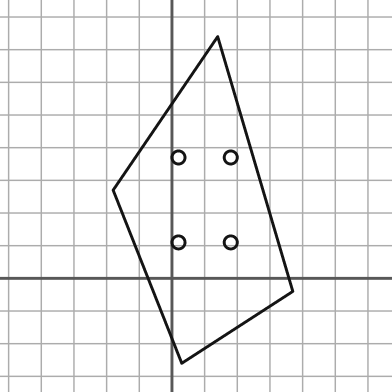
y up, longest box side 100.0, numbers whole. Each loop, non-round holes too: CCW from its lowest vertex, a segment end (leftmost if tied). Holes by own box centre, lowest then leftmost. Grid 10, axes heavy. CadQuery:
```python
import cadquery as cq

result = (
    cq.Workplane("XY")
    .moveTo(3.0, -26.0)
    .lineTo(37.0, -4.0)
    .lineTo(14.0, 74.0)
    .lineTo(-18.0, 27.0)
    .close()
    .moveTo(2.0, 11.0)
    .circle(2.0)
    .moveTo(18.0, 11.0)
    .circle(2.0)
    .moveTo(2.0, 37.0)
    .circle(2.0)
    .moveTo(18.0, 37.0)
    .circle(2.0)
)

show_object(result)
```